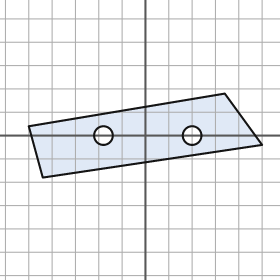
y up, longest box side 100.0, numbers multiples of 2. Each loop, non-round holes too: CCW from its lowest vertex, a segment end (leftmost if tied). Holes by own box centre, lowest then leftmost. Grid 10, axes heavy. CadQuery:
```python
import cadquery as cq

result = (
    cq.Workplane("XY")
    .moveTo(-44.0, -18.0)
    .lineTo(50.0, -4.0)
    .lineTo(34.0, 18.0)
    .lineTo(-50.0, 4.0)
    .close()
    .moveTo(-18.0, 0.0)
    .circle(4.0)
    .moveTo(20.0, 0.0)
    .circle(4.0)
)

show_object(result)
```